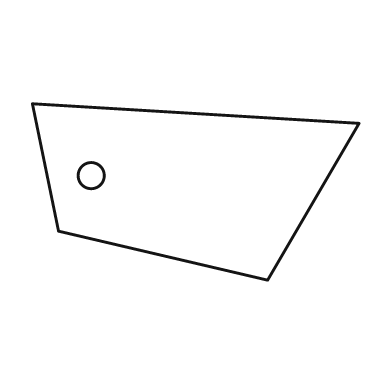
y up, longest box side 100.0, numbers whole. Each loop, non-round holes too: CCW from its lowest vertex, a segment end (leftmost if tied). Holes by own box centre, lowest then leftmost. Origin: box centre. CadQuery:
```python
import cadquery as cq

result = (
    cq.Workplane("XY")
    .moveTo(22.0, -27.0)
    .lineTo(50.0, 21.0)
    .lineTo(-50.0, 27.0)
    .lineTo(-42.0, -12.0)
    .close()
    .moveTo(-32.0, 5.0)
    .circle(4.0)
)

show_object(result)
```